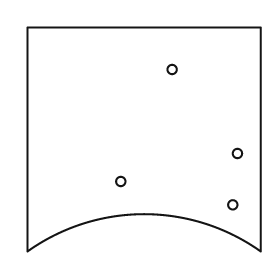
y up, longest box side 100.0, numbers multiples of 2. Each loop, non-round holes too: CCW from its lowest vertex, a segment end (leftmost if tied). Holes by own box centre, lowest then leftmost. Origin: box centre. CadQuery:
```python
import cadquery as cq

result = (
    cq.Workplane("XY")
    .moveTo(-50.0, -48.0)
    .threePointArc((0.0, -32.0), (50.0, -48.0))
    .lineTo(50.0, 48.0)
    .lineTo(-50.0, 48.0)
    .close()
    .moveTo(38.0, -28.0)
    .circle(2.0)
    .moveTo(-10.0, -18.0)
    .circle(2.0)
    .moveTo(40.0, -6.0)
    .circle(2.0)
    .moveTo(12.0, 30.0)
    .circle(2.0)
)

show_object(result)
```